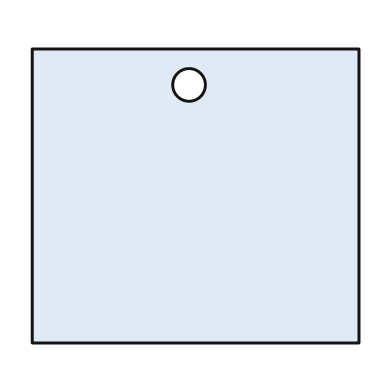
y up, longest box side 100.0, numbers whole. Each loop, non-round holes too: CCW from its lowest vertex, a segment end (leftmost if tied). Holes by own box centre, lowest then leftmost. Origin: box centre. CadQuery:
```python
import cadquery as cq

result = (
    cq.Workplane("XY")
    .moveTo(-50.0, -45.0)
    .lineTo(50.0, -45.0)
    .lineTo(50.0, 45.0)
    .lineTo(-50.0, 45.0)
    .close()
    .moveTo(-2.0, 34.0)
    .circle(5.0)
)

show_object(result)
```